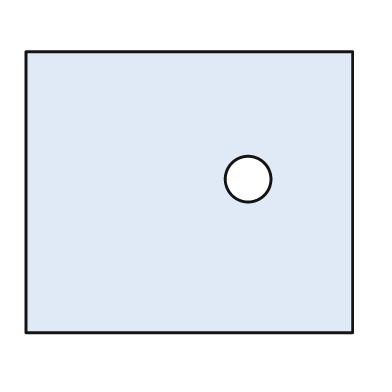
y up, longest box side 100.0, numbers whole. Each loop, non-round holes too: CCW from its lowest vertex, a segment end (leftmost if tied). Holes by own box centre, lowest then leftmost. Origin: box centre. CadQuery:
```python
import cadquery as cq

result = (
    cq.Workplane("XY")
    .moveTo(-50.0, -43.0)
    .lineTo(50.0, -43.0)
    .lineTo(50.0, 43.0)
    .lineTo(-50.0, 43.0)
    .close()
    .moveTo(18.0, 4.0)
    .circle(7.0)
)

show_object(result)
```